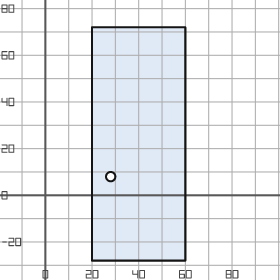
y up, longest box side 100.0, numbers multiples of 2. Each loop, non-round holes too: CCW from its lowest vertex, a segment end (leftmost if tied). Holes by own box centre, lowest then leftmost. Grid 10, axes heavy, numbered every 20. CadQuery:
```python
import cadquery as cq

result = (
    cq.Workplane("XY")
    .moveTo(20.0, -28.0)
    .lineTo(60.0, -28.0)
    .lineTo(60.0, 72.0)
    .lineTo(20.0, 72.0)
    .close()
    .moveTo(28.0, 8.0)
    .circle(2.0)
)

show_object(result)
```